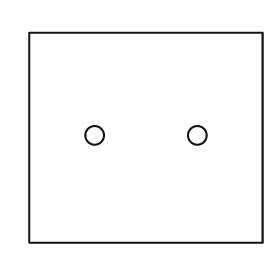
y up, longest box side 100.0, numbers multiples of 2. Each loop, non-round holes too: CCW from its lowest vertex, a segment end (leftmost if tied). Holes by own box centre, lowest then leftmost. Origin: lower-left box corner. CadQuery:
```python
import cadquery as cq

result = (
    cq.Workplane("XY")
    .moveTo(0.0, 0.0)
    .lineTo(100.0, 0.0)
    .lineTo(100.0, 90.0)
    .lineTo(0.0, 90.0)
    .close()
    .moveTo(28.0, 46.0)
    .circle(4.0)
    .moveTo(72.0, 46.0)
    .circle(4.0)
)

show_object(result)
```